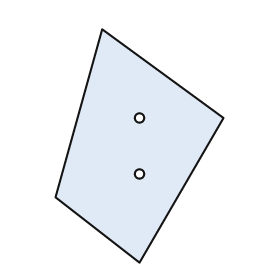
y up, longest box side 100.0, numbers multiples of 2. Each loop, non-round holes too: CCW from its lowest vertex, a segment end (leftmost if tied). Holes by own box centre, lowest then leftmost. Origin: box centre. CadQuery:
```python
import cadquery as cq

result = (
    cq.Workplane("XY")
    .moveTo(0.0, -50.0)
    .lineTo(36.0, 12.0)
    .lineTo(-16.0, 50.0)
    .lineTo(-36.0, -22.0)
    .close()
    .moveTo(0.0, -12.0)
    .circle(2.0)
    .moveTo(0.0, 12.0)
    .circle(2.0)
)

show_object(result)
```